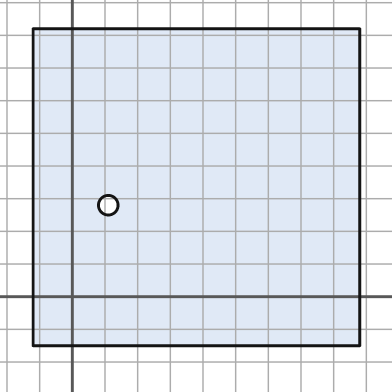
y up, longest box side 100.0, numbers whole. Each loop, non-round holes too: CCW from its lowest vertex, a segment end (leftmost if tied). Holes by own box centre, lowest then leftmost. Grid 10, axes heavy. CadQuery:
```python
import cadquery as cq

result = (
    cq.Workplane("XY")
    .moveTo(-12.0, -15.0)
    .lineTo(88.0, -15.0)
    .lineTo(88.0, 82.0)
    .lineTo(-12.0, 82.0)
    .close()
    .moveTo(11.0, 28.0)
    .circle(3.0)
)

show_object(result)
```